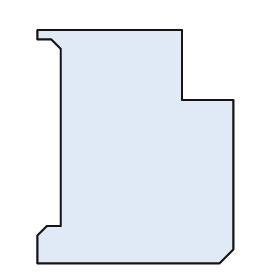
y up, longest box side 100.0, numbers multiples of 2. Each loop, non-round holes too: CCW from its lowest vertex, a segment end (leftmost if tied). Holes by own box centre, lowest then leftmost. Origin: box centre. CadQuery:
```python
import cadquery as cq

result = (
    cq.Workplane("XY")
    .moveTo(-42.0, -50.0)
    .lineTo(36.0, -50.0)
    .lineTo(42.0, -44.0)
    .lineTo(42.0, 20.0)
    .lineTo(20.0, 20.0)
    .lineTo(20.0, 50.0)
    .lineTo(-42.0, 50.0)
    .lineTo(-42.0, 46.0)
    .lineTo(-36.0, 46.0)
    .lineTo(-32.0, 42.0)
    .lineTo(-32.0, -34.0)
    .lineTo(-38.0, -34.0)
    .lineTo(-42.0, -38.0)
    .close()
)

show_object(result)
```